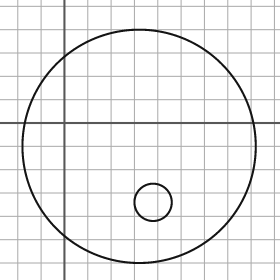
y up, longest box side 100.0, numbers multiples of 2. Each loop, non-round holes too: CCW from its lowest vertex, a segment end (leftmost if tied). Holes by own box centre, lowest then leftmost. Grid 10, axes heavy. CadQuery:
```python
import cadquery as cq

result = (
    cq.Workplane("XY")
    .moveTo(32.0, -10.0)
    .circle(50.0)
    .moveTo(38.0, -34.0)
    .circle(8.0)
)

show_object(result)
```